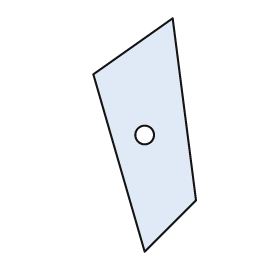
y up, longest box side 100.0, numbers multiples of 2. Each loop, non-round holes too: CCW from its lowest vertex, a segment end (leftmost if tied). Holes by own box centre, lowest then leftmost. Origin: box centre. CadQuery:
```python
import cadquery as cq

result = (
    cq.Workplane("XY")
    .moveTo(0.0, -50.0)
    .lineTo(22.0, -28.0)
    .lineTo(12.0, 50.0)
    .lineTo(-22.0, 26.0)
    .close()
    .moveTo(0.0, 0.0)
    .circle(4.0)
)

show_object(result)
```